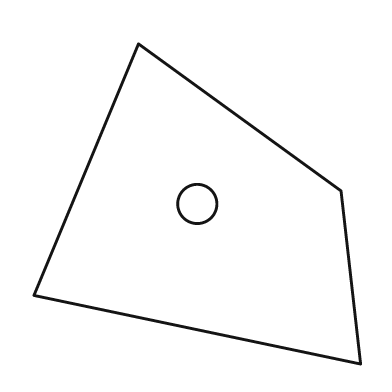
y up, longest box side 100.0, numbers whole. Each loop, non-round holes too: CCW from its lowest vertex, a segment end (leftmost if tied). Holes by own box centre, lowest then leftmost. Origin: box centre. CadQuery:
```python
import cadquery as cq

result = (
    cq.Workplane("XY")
    .moveTo(50.0, -49.0)
    .lineTo(44.0, 4.0)
    .lineTo(-18.0, 49.0)
    .lineTo(-50.0, -28.0)
    .close()
    .moveTo(0.0, 0.0)
    .circle(6.0)
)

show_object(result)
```